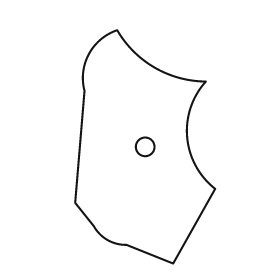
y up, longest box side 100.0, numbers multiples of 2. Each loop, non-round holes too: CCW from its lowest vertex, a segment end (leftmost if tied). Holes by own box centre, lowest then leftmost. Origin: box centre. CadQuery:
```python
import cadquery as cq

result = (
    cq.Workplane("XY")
    .moveTo(12.0, -50.0)
    .lineTo(30.0, -18.0)
    .threePointArc((18.0, 4.0), (26.0, 28.0))
    .threePointArc((4.0, 34.0), (-12.0, 50.0))
    .threePointArc((-24.0, 40.0), (-26.0, 24.0))
    .lineTo(-30.0, -24.0)
    .lineTo(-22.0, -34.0)
    .threePointArc((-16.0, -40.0), (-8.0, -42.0))
    .close()
    .moveTo(0.0, 0.0)
    .circle(4.0)
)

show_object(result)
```